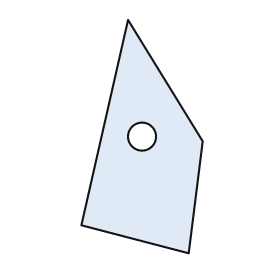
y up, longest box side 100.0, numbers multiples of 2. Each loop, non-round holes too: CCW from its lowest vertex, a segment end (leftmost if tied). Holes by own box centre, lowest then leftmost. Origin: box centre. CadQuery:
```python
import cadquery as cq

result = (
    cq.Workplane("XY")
    .moveTo(20.0, -50.0)
    .lineTo(26.0, -2.0)
    .lineTo(-6.0, 50.0)
    .lineTo(-26.0, -38.0)
    .close()
    .moveTo(0.0, 0.0)
    .circle(6.0)
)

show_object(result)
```